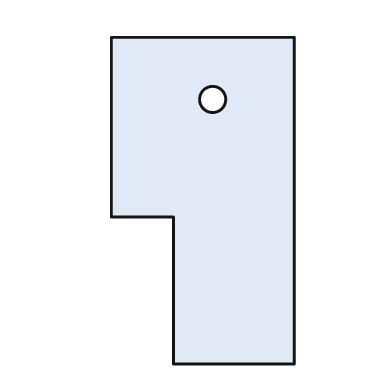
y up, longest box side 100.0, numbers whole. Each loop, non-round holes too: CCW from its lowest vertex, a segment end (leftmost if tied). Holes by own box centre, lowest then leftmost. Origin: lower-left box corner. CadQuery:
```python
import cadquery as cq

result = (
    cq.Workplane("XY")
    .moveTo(19.0, 0.0)
    .lineTo(56.0, 0.0)
    .lineTo(56.0, 100.0)
    .lineTo(0.0, 100.0)
    .lineTo(0.0, 45.0)
    .lineTo(19.0, 45.0)
    .close()
    .moveTo(31.0, 81.0)
    .circle(4.0)
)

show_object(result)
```